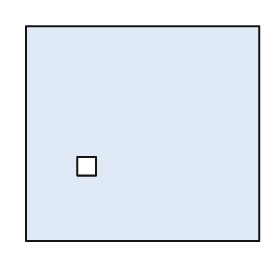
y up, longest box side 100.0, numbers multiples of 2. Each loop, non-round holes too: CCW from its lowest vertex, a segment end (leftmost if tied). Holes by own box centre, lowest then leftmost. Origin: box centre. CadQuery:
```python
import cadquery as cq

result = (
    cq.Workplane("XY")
    .moveTo(-50.0, -46.0)
    .lineTo(50.0, -46.0)
    .lineTo(50.0, 46.0)
    .lineTo(-50.0, 46.0)
    .close()
    .moveTo(-28.0, -18.0)
    .lineTo(-20.0, -18.0)
    .lineTo(-20.0, -10.0)
    .lineTo(-28.0, -10.0)
    .close()
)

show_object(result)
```